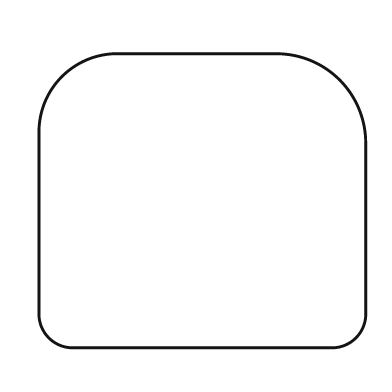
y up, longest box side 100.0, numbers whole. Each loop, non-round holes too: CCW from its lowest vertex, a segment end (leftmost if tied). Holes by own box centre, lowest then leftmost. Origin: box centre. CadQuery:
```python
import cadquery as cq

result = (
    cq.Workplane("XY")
    .moveTo(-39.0, -45.0)
    .lineTo(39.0, -45.0)
    .threePointArc((47.0, -42.0), (50.0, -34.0))
    .lineTo(50.0, 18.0)
    .threePointArc((42.0, 37.0), (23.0, 45.0))
    .lineTo(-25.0, 45.0)
    .threePointArc((-43.0, 38.0), (-50.0, 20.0))
    .lineTo(-50.0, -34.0)
    .threePointArc((-47.0, -42.0), (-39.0, -45.0))
    .close()
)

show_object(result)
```